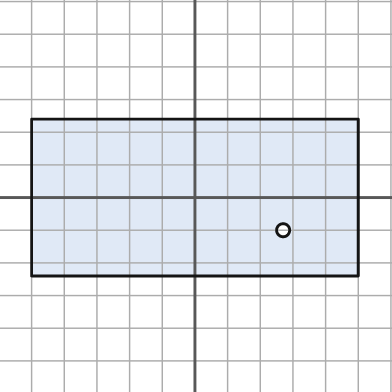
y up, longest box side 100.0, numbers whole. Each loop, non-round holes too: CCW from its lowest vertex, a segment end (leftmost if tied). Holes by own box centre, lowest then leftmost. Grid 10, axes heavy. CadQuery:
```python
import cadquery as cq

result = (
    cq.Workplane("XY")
    .moveTo(-50.0, -24.0)
    .lineTo(50.0, -24.0)
    .lineTo(50.0, 24.0)
    .lineTo(-50.0, 24.0)
    .close()
    .moveTo(27.0, -10.0)
    .circle(2.0)
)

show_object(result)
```